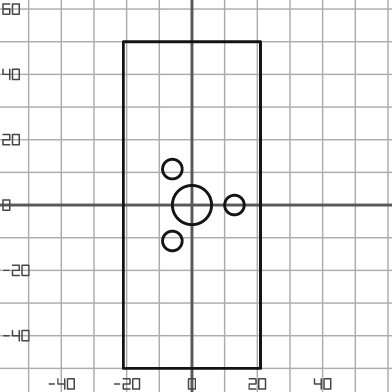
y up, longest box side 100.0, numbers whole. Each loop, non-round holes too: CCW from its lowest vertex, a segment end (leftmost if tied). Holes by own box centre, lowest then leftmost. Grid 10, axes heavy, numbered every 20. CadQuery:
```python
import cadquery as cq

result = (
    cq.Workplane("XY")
    .moveTo(-21.0, -50.0)
    .lineTo(21.0, -50.0)
    .lineTo(21.0, 50.0)
    .lineTo(-21.0, 50.0)
    .close()
    .moveTo(-6.0, -11.0)
    .circle(3.0)
    .moveTo(0.0, 0.0)
    .circle(6.0)
    .moveTo(13.0, 0.0)
    .circle(3.0)
    .moveTo(-6.0, 11.0)
    .circle(3.0)
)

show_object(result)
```